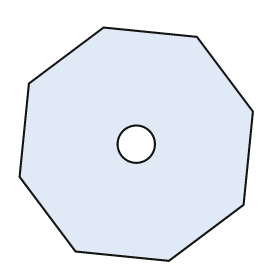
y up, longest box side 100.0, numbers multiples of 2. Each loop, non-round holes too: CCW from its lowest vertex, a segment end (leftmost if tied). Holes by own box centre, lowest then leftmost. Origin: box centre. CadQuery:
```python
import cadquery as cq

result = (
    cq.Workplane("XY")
    .moveTo(14.0, -50.0)
    .lineTo(46.0, -26.0)
    .lineTo(50.0, 14.0)
    .lineTo(26.0, 46.0)
    .lineTo(-14.0, 50.0)
    .lineTo(-46.0, 26.0)
    .lineTo(-50.0, -14.0)
    .lineTo(-26.0, -46.0)
    .close()
    .moveTo(0.0, 0.0)
    .circle(8.0)
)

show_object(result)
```